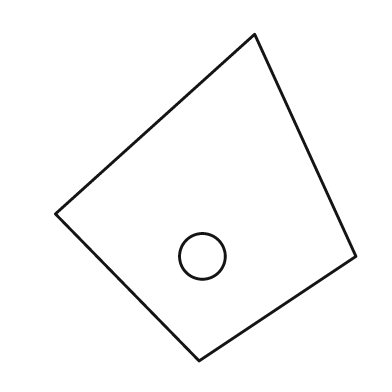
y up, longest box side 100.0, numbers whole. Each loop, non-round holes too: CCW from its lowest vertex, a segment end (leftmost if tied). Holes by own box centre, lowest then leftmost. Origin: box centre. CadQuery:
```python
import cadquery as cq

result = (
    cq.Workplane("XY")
    .moveTo(-2.0, -50.0)
    .lineTo(46.0, -18.0)
    .lineTo(15.0, 50.0)
    .lineTo(-46.0, -5.0)
    .close()
    .moveTo(-1.0, -18.0)
    .circle(7.0)
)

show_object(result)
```